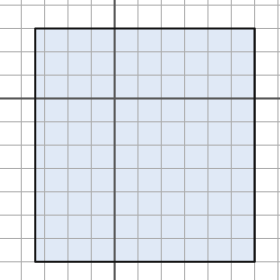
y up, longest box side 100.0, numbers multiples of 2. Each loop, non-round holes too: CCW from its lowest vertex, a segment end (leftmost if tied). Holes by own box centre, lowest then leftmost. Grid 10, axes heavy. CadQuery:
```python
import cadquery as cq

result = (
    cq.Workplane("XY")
    .moveTo(-34.0, -70.0)
    .lineTo(60.0, -70.0)
    .lineTo(60.0, 30.0)
    .lineTo(-34.0, 30.0)
    .close()
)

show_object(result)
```